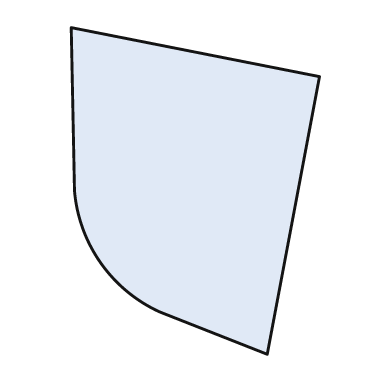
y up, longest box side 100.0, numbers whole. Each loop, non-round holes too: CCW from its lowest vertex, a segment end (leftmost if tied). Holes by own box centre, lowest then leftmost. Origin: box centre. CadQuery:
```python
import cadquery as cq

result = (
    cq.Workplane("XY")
    .moveTo(22.0, -50.0)
    .lineTo(38.0, 35.0)
    .lineTo(-38.0, 50.0)
    .lineTo(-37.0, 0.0)
    .threePointArc((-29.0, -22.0), (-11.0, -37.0))
    .close()
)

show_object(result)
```